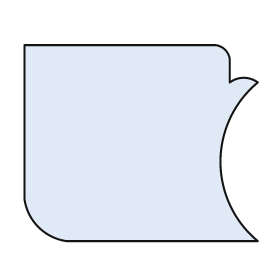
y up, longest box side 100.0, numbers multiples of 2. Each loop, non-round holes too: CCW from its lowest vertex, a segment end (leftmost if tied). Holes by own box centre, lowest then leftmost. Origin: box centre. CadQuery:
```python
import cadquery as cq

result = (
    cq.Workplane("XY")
    .moveTo(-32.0, -42.0)
    .lineTo(50.0, -42.0)
    .threePointArc((34.0, -8.0), (50.0, 26.0))
    .threePointArc((44.0, 28.0), (38.0, 26.0))
    .lineTo(38.0, 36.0)
    .threePointArc((36.0, 40.0), (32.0, 42.0))
    .lineTo(-50.0, 42.0)
    .lineTo(-50.0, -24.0)
    .threePointArc((-44.0, -36.0), (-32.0, -42.0))
    .close()
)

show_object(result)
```